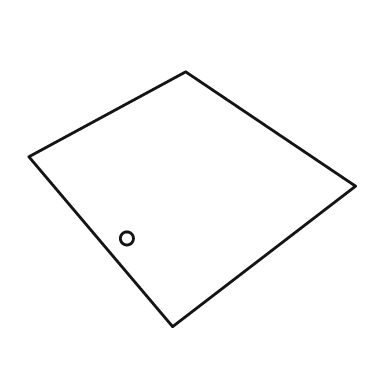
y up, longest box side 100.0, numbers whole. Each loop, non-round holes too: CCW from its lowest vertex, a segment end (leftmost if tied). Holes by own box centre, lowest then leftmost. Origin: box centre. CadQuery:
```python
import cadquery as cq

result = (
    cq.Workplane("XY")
    .moveTo(-6.0, -39.0)
    .lineTo(50.0, 4.0)
    .lineTo(-2.0, 39.0)
    .lineTo(-50.0, 13.0)
    .close()
    .moveTo(-20.0, -12.0)
    .circle(2.0)
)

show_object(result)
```